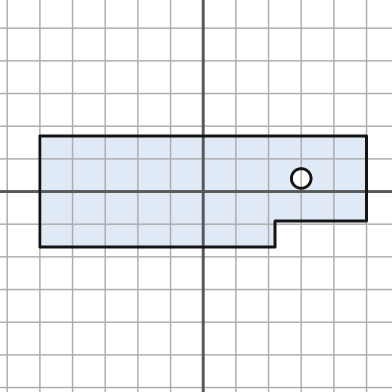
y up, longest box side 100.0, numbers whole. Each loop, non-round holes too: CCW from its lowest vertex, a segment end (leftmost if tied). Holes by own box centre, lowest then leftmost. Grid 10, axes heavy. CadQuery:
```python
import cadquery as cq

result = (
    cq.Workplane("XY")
    .moveTo(-50.0, -17.0)
    .lineTo(22.0, -17.0)
    .lineTo(22.0, -9.0)
    .lineTo(50.0, -9.0)
    .lineTo(50.0, 17.0)
    .lineTo(-50.0, 17.0)
    .close()
    .moveTo(30.0, 4.0)
    .circle(3.0)
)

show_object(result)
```